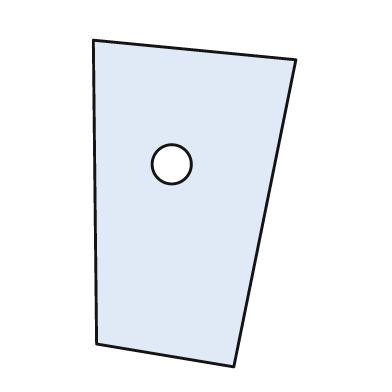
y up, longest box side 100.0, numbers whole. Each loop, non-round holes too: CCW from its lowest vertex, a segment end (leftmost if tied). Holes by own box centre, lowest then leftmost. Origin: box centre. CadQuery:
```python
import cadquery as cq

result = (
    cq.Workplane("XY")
    .moveTo(12.0, -50.0)
    .lineTo(31.0, 44.0)
    .lineTo(-31.0, 50.0)
    .lineTo(-30.0, -43.0)
    .close()
    .moveTo(-7.0, 12.0)
    .circle(6.0)
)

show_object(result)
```